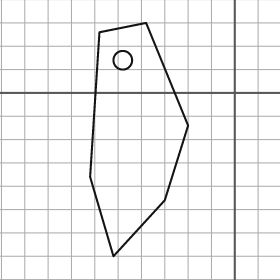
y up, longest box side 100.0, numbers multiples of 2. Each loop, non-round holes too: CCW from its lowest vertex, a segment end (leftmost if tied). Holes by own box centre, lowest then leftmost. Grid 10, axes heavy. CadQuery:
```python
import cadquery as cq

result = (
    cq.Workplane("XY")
    .moveTo(-52.0, -70.0)
    .lineTo(-30.0, -46.0)
    .lineTo(-20.0, -14.0)
    .lineTo(-38.0, 30.0)
    .lineTo(-58.0, 26.0)
    .lineTo(-62.0, -36.0)
    .close()
    .moveTo(-48.0, 14.0)
    .circle(4.0)
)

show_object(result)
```